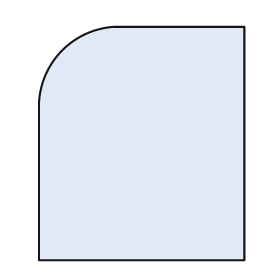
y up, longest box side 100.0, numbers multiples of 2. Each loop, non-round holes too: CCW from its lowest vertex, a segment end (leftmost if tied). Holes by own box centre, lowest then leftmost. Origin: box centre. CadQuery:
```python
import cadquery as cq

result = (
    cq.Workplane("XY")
    .moveTo(-44.0, -50.0)
    .lineTo(44.0, -50.0)
    .lineTo(44.0, 50.0)
    .lineTo(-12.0, 50.0)
    .threePointArc((-34.0, 40.0), (-44.0, 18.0))
    .close()
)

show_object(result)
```